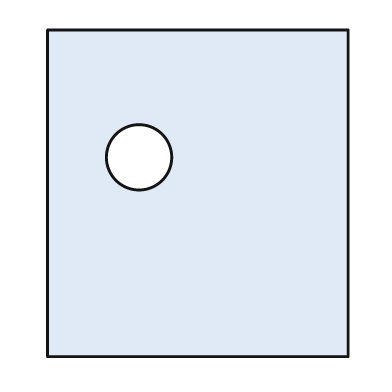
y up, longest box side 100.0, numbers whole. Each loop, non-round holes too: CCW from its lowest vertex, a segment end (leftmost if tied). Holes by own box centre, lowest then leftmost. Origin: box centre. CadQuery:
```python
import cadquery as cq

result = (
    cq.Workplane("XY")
    .moveTo(-46.0, -50.0)
    .lineTo(46.0, -50.0)
    .lineTo(46.0, 50.0)
    .lineTo(-46.0, 50.0)
    .close()
    .moveTo(-18.0, 11.0)
    .circle(10.0)
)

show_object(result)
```